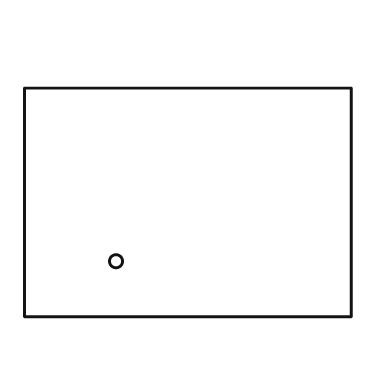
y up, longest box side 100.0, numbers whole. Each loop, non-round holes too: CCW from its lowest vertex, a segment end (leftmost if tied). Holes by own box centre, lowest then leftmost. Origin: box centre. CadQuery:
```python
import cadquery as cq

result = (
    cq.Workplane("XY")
    .moveTo(-50.0, -35.0)
    .lineTo(50.0, -35.0)
    .lineTo(50.0, 35.0)
    .lineTo(-50.0, 35.0)
    .close()
    .moveTo(-22.0, -18.0)
    .circle(2.0)
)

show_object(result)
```